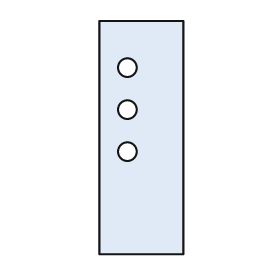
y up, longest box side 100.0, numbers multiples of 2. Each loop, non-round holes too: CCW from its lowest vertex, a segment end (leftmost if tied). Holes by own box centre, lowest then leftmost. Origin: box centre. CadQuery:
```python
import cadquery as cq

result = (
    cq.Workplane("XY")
    .moveTo(-18.0, -50.0)
    .lineTo(18.0, -50.0)
    .lineTo(18.0, 50.0)
    .lineTo(-18.0, 50.0)
    .close()
    .moveTo(-6.0, -6.0)
    .circle(4.0)
    .moveTo(-6.0, 12.0)
    .circle(4.0)
    .moveTo(-6.0, 30.0)
    .circle(4.0)
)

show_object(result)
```